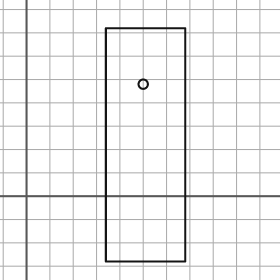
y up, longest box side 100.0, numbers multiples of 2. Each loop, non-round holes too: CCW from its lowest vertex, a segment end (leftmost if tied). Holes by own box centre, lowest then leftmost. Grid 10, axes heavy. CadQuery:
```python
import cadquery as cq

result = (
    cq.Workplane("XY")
    .moveTo(34.0, -28.0)
    .lineTo(68.0, -28.0)
    .lineTo(68.0, 72.0)
    .lineTo(34.0, 72.0)
    .close()
    .moveTo(50.0, 48.0)
    .circle(2.0)
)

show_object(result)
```